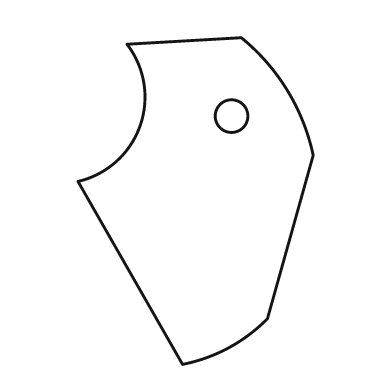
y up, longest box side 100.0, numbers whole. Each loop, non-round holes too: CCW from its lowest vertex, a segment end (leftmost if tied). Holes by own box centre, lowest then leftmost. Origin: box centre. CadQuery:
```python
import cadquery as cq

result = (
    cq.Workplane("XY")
    .moveTo(-4.0, -50.0)
    .threePointArc((10.0, -45.0), (22.0, -36.0))
    .lineTo(36.0, 14.0)
    .threePointArc((28.0, 34.0), (14.0, 50.0))
    .lineTo(-21.0, 48.0)
    .threePointArc((-17.0, 23.0), (-36.0, 6.0))
    .close()
    .moveTo(11.0, 26.0)
    .circle(5.0)
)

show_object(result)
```